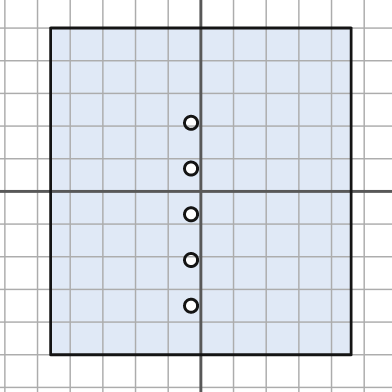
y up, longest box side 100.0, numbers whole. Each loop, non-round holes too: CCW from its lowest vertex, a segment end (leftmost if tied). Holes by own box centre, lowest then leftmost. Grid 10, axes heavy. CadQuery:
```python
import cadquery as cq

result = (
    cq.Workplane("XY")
    .moveTo(-46.0, -50.0)
    .lineTo(46.0, -50.0)
    .lineTo(46.0, 50.0)
    .lineTo(-46.0, 50.0)
    .close()
    .moveTo(-3.0, -35.0)
    .circle(2.0)
    .moveTo(-3.0, -21.0)
    .circle(2.0)
    .moveTo(-3.0, -7.0)
    .circle(2.0)
    .moveTo(-3.0, 7.0)
    .circle(2.0)
    .moveTo(-3.0, 21.0)
    .circle(2.0)
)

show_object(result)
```